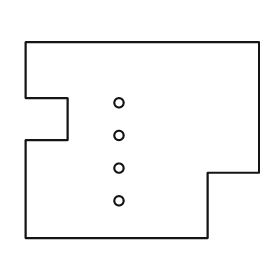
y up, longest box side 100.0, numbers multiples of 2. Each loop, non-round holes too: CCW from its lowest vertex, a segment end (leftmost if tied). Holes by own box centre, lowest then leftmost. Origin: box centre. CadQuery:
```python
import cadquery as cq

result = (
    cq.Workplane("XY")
    .moveTo(-50.0, -42.0)
    .lineTo(28.0, -42.0)
    .lineTo(28.0, -14.0)
    .lineTo(50.0, -14.0)
    .lineTo(50.0, 42.0)
    .lineTo(-50.0, 42.0)
    .lineTo(-50.0, 18.0)
    .lineTo(-32.0, 18.0)
    .lineTo(-32.0, 0.0)
    .lineTo(-50.0, 0.0)
    .close()
    .moveTo(-10.0, -26.0)
    .circle(2.0)
    .moveTo(-10.0, -12.0)
    .circle(2.0)
    .moveTo(-10.0, 2.0)
    .circle(2.0)
    .moveTo(-10.0, 16.0)
    .circle(2.0)
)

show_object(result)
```